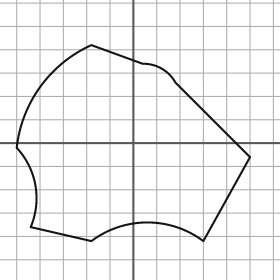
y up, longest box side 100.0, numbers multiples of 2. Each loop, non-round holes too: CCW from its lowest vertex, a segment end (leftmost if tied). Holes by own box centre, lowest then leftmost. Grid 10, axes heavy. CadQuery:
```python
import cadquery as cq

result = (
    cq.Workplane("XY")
    .moveTo(-18.0, -42.0)
    .threePointArc((6.0, -34.0), (30.0, -42.0))
    .lineTo(50.0, -6.0)
    .lineTo(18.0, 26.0)
    .threePointArc((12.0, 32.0), (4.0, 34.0))
    .lineTo(-18.0, 42.0)
    .threePointArc((-40.0, 24.0), (-50.0, -2.0))
    .threePointArc((-42.0, -18.0), (-44.0, -36.0))
    .close()
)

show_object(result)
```